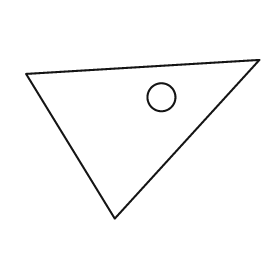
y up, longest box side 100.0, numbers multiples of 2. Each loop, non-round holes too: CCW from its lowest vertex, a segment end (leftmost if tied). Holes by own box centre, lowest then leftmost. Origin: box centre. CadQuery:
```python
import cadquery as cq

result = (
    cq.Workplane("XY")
    .moveTo(-12.0, -34.0)
    .lineTo(50.0, 34.0)
    .lineTo(-50.0, 28.0)
    .close()
    .moveTo(8.0, 18.0)
    .circle(6.0)
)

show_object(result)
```